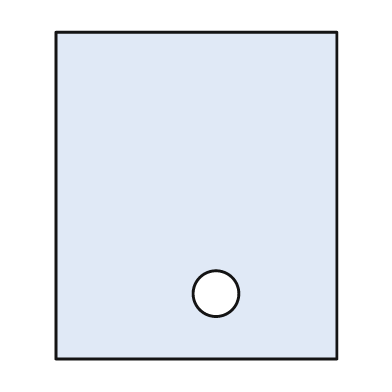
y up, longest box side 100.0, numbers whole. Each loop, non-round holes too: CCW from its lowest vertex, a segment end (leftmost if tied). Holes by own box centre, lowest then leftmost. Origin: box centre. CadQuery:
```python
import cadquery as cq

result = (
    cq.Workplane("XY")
    .moveTo(-43.0, -50.0)
    .lineTo(43.0, -50.0)
    .lineTo(43.0, 50.0)
    .lineTo(-43.0, 50.0)
    .close()
    .moveTo(6.0, -30.0)
    .circle(7.0)
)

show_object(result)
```